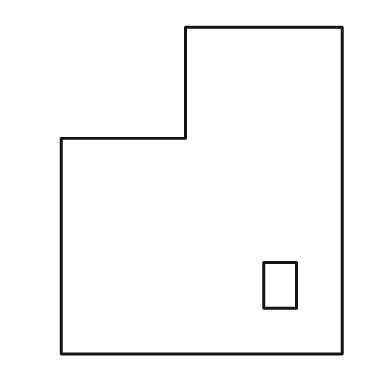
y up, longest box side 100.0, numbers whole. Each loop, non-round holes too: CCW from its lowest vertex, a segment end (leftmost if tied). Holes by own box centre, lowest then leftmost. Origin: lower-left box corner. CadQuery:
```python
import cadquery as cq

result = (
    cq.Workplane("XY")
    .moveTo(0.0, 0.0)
    .lineTo(86.0, 0.0)
    .lineTo(86.0, 100.0)
    .lineTo(38.0, 100.0)
    .lineTo(38.0, 66.0)
    .lineTo(0.0, 66.0)
    .close()
    .moveTo(62.0, 14.0)
    .lineTo(72.0, 14.0)
    .lineTo(72.0, 28.0)
    .lineTo(62.0, 28.0)
    .close()
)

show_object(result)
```